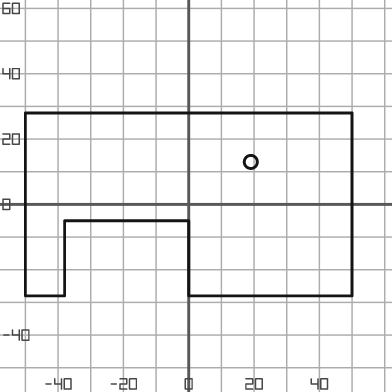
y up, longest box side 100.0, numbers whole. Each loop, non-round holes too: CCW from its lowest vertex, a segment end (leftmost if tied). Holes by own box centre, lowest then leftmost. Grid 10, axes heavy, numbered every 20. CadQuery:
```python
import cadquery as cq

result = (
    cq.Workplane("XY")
    .moveTo(-50.0, -28.0)
    .lineTo(-38.0, -28.0)
    .lineTo(-38.0, -5.0)
    .lineTo(0.0, -5.0)
    .lineTo(0.0, -28.0)
    .lineTo(50.0, -28.0)
    .lineTo(50.0, 28.0)
    .lineTo(-50.0, 28.0)
    .close()
    .moveTo(19.0, 13.0)
    .circle(2.0)
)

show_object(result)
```